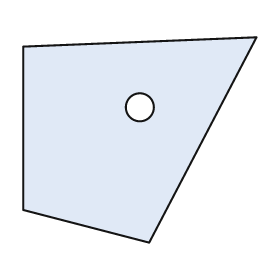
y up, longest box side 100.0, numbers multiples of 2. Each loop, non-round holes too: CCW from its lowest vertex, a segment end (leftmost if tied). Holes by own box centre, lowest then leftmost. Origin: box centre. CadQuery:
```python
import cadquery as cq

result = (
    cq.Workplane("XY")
    .moveTo(4.0, -44.0)
    .lineTo(50.0, 44.0)
    .lineTo(-50.0, 40.0)
    .lineTo(-50.0, -30.0)
    .close()
    .moveTo(0.0, 14.0)
    .circle(6.0)
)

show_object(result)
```